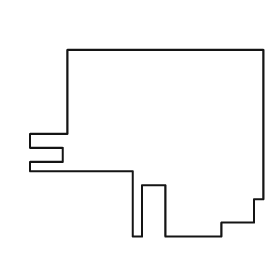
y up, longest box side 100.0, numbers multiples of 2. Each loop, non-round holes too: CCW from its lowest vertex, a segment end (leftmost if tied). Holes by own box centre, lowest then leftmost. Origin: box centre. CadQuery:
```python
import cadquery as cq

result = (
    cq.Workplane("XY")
    .moveTo(-6.0, -40.0)
    .lineTo(-2.0, -40.0)
    .lineTo(-2.0, -18.0)
    .lineTo(8.0, -18.0)
    .lineTo(8.0, -40.0)
    .lineTo(32.0, -40.0)
    .lineTo(32.0, -34.0)
    .lineTo(46.0, -34.0)
    .lineTo(46.0, -24.0)
    .lineTo(50.0, -24.0)
    .lineTo(50.0, 40.0)
    .lineTo(-34.0, 40.0)
    .lineTo(-34.0, 4.0)
    .lineTo(-50.0, 4.0)
    .lineTo(-50.0, -2.0)
    .lineTo(-36.0, -2.0)
    .lineTo(-36.0, -8.0)
    .lineTo(-50.0, -8.0)
    .lineTo(-50.0, -12.0)
    .lineTo(-6.0, -12.0)
    .close()
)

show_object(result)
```